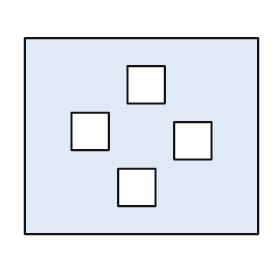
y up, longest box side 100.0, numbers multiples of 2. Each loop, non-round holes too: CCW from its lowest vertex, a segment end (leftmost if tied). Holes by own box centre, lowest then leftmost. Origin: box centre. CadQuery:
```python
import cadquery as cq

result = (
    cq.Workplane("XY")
    .moveTo(-50.0, -42.0)
    .lineTo(50.0, -42.0)
    .lineTo(50.0, 42.0)
    .lineTo(-50.0, 42.0)
    .close()
    .moveTo(-10.0, -30.0)
    .lineTo(6.0, -30.0)
    .lineTo(6.0, -14.0)
    .lineTo(-10.0, -14.0)
    .close()
    .moveTo(14.0, -10.0)
    .lineTo(30.0, -10.0)
    .lineTo(30.0, 6.0)
    .lineTo(14.0, 6.0)
    .close()
    .moveTo(-30.0, -6.0)
    .lineTo(-14.0, -6.0)
    .lineTo(-14.0, 10.0)
    .lineTo(-30.0, 10.0)
    .close()
    .moveTo(-6.0, 14.0)
    .lineTo(10.0, 14.0)
    .lineTo(10.0, 30.0)
    .lineTo(-6.0, 30.0)
    .close()
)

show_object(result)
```